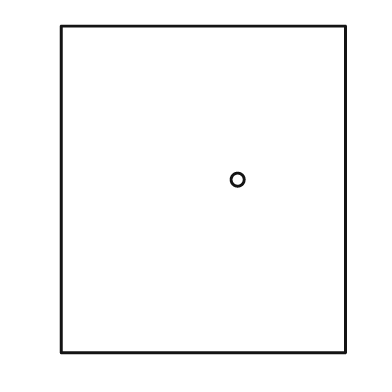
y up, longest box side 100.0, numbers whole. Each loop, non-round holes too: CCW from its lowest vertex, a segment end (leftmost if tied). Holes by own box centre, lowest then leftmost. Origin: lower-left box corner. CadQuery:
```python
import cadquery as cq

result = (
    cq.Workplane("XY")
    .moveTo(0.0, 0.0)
    .lineTo(87.0, 0.0)
    .lineTo(87.0, 100.0)
    .lineTo(0.0, 100.0)
    .close()
    .moveTo(54.0, 53.0)
    .circle(2.0)
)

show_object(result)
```